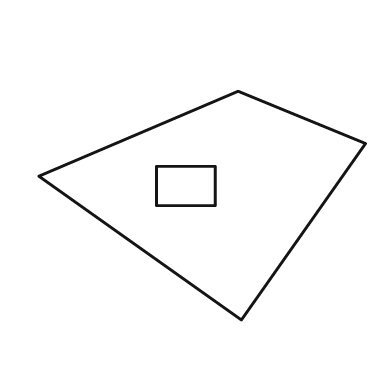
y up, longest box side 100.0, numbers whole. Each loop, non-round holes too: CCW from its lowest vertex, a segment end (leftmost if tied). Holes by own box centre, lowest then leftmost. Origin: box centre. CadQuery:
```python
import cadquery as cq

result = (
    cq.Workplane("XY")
    .moveTo(12.0, -35.0)
    .lineTo(50.0, 19.0)
    .lineTo(11.0, 35.0)
    .lineTo(-50.0, 9.0)
    .close()
    .moveTo(-14.0, 0.0)
    .lineTo(4.0, 0.0)
    .lineTo(4.0, 12.0)
    .lineTo(-14.0, 12.0)
    .close()
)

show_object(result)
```